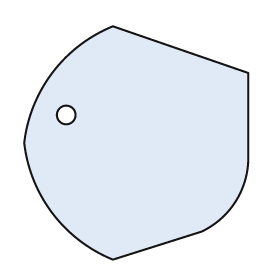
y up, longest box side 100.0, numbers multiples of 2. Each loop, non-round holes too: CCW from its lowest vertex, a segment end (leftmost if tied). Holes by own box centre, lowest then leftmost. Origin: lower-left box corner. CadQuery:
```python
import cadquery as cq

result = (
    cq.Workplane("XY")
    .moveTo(38.0, 0.0)
    .lineTo(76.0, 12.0)
    .threePointArc((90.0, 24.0), (96.0, 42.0))
    .lineTo(96.0, 80.0)
    .lineTo(38.0, 100.0)
    .threePointArc((12.0, 80.0), (0.0, 50.0))
    .threePointArc((12.0, 20.0), (38.0, 0.0))
    .close()
    .moveTo(18.0, 62.0)
    .circle(4.0)
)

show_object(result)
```